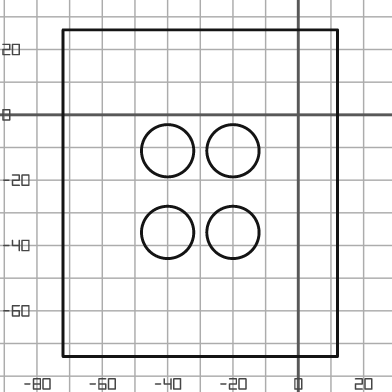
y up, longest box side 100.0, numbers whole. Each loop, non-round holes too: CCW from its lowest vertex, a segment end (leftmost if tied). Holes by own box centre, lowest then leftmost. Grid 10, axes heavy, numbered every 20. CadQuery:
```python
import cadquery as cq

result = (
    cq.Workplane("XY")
    .moveTo(-72.0, -74.0)
    .lineTo(12.0, -74.0)
    .lineTo(12.0, 26.0)
    .lineTo(-72.0, 26.0)
    .close()
    .moveTo(-40.0, -36.0)
    .circle(8.0)
    .moveTo(-20.0, -36.0)
    .circle(8.0)
    .moveTo(-40.0, -11.0)
    .circle(8.0)
    .moveTo(-20.0, -11.0)
    .circle(8.0)
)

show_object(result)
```